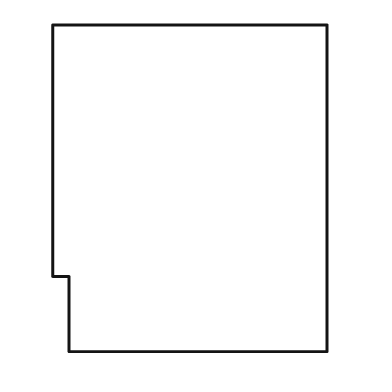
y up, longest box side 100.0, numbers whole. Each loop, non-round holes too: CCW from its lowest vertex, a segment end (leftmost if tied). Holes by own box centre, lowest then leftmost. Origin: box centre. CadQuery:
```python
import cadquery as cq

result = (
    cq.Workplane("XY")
    .moveTo(-37.0, -50.0)
    .lineTo(42.0, -50.0)
    .lineTo(42.0, 50.0)
    .lineTo(-42.0, 50.0)
    .lineTo(-42.0, -27.0)
    .lineTo(-37.0, -27.0)
    .close()
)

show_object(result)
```